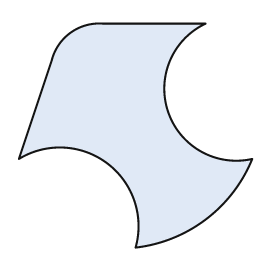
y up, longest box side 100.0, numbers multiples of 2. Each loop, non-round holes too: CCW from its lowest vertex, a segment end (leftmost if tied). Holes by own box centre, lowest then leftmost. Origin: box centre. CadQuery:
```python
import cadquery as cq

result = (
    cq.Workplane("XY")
    .moveTo(0.0, -48.0)
    .threePointArc((30.0, -36.0), (50.0, -10.0))
    .threePointArc((14.0, 10.0), (30.0, 48.0))
    .lineTo(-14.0, 48.0)
    .threePointArc((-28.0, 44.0), (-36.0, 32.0))
    .lineTo(-50.0, -10.0)
    .threePointArc((-12.0, -12.0), (0.0, -48.0))
    .close()
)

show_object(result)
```